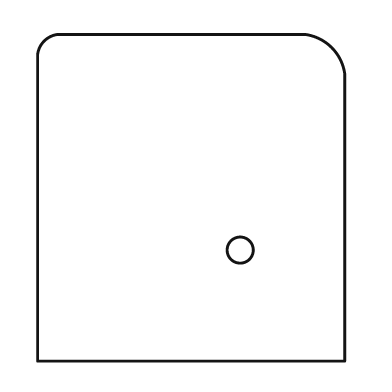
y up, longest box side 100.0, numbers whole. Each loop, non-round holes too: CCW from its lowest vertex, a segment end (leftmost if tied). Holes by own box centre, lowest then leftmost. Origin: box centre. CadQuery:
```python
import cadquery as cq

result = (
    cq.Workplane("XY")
    .moveTo(-47.0, -50.0)
    .lineTo(47.0, -50.0)
    .lineTo(47.0, 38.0)
    .threePointArc((43.0, 46.0), (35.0, 50.0))
    .lineTo(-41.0, 50.0)
    .threePointArc((-45.0, 48.0), (-47.0, 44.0))
    .close()
    .moveTo(15.0, -16.0)
    .circle(4.0)
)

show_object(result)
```